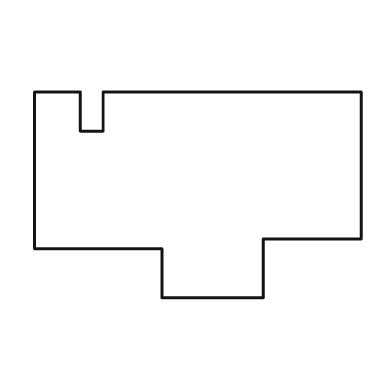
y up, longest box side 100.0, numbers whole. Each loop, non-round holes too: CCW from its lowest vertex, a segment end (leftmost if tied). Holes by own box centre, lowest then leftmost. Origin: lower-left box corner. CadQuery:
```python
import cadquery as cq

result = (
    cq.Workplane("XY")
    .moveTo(39.0, 0.0)
    .lineTo(70.0, 0.0)
    .lineTo(70.0, 18.0)
    .lineTo(100.0, 18.0)
    .lineTo(100.0, 63.0)
    .lineTo(21.0, 63.0)
    .lineTo(21.0, 51.0)
    .lineTo(14.0, 51.0)
    .lineTo(14.0, 63.0)
    .lineTo(0.0, 63.0)
    .lineTo(0.0, 15.0)
    .lineTo(39.0, 15.0)
    .close()
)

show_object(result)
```